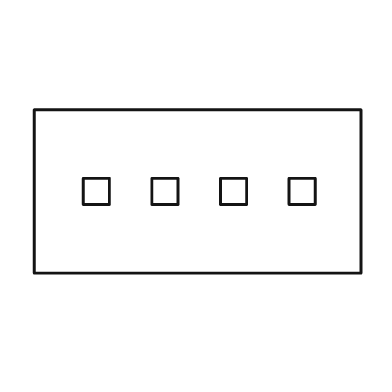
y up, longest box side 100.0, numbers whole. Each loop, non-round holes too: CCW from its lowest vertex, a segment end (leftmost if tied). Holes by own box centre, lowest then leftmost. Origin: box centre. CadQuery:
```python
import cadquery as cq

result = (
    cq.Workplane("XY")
    .moveTo(-50.0, -25.0)
    .lineTo(50.0, -25.0)
    .lineTo(50.0, 25.0)
    .lineTo(-50.0, 25.0)
    .close()
    .moveTo(-35.0, -4.0)
    .lineTo(-27.0, -4.0)
    .lineTo(-27.0, 4.0)
    .lineTo(-35.0, 4.0)
    .close()
    .moveTo(-14.0, -4.0)
    .lineTo(-6.0, -4.0)
    .lineTo(-6.0, 4.0)
    .lineTo(-14.0, 4.0)
    .close()
    .moveTo(7.0, -4.0)
    .lineTo(15.0, -4.0)
    .lineTo(15.0, 4.0)
    .lineTo(7.0, 4.0)
    .close()
    .moveTo(28.0, -4.0)
    .lineTo(36.0, -4.0)
    .lineTo(36.0, 4.0)
    .lineTo(28.0, 4.0)
    .close()
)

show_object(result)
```